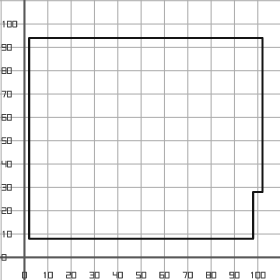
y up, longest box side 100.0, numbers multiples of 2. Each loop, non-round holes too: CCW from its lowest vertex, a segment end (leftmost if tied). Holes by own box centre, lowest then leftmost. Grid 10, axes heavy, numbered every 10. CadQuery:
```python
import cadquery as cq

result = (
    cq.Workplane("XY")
    .moveTo(2.0, 8.0)
    .lineTo(98.0, 8.0)
    .lineTo(98.0, 28.0)
    .lineTo(102.0, 28.0)
    .lineTo(102.0, 94.0)
    .lineTo(2.0, 94.0)
    .close()
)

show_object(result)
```